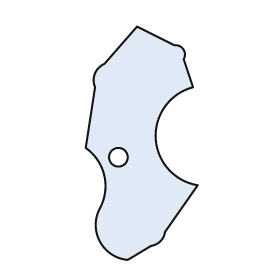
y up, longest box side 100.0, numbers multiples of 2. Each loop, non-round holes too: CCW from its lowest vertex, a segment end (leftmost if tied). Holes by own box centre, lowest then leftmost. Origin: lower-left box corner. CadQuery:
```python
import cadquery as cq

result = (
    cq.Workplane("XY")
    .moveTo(18.0, 0.0)
    .lineTo(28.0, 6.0)
    .threePointArc((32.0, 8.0), (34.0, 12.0))
    .lineTo(48.0, 32.0)
    .threePointArc((30.0, 52.0), (46.0, 74.0))
    .lineTo(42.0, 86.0)
    .threePointArc((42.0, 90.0), (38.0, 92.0))
    .lineTo(22.0, 100.0)
    .lineTo(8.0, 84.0)
    .threePointArc((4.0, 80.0), (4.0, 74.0))
    .lineTo(0.0, 48.0)
    .threePointArc((8.0, 36.0), (6.0, 22.0))
    .threePointArc((6.0, 8.0), (18.0, 0.0))
    .close()
    .moveTo(14.0, 44.0)
    .circle(4.0)
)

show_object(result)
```